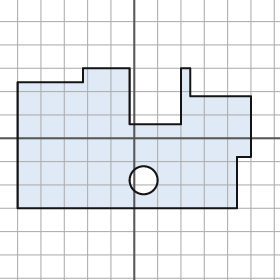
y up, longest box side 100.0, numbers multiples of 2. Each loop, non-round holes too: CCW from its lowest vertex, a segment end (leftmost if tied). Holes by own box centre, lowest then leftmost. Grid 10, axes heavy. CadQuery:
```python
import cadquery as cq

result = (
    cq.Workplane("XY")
    .moveTo(-50.0, -30.0)
    .lineTo(44.0, -30.0)
    .lineTo(44.0, -8.0)
    .lineTo(50.0, -8.0)
    .lineTo(50.0, 18.0)
    .lineTo(24.0, 18.0)
    .lineTo(24.0, 30.0)
    .lineTo(20.0, 30.0)
    .lineTo(20.0, 6.0)
    .lineTo(-2.0, 6.0)
    .lineTo(-2.0, 30.0)
    .lineTo(-22.0, 30.0)
    .lineTo(-22.0, 24.0)
    .lineTo(-50.0, 24.0)
    .close()
    .moveTo(4.0, -18.0)
    .circle(6.0)
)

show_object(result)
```